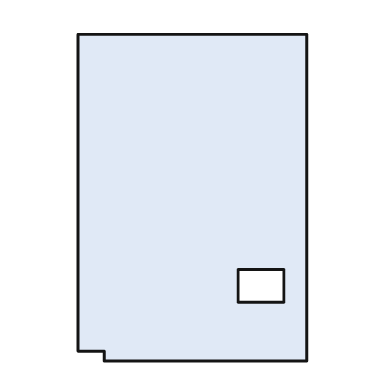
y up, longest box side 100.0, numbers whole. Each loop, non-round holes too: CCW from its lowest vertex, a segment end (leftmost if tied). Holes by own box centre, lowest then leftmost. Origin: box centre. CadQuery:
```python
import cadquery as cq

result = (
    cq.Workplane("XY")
    .moveTo(-27.0, -50.0)
    .lineTo(35.0, -50.0)
    .lineTo(35.0, 50.0)
    .lineTo(-35.0, 50.0)
    .lineTo(-35.0, -47.0)
    .lineTo(-27.0, -47.0)
    .close()
    .moveTo(14.0, -32.0)
    .lineTo(28.0, -32.0)
    .lineTo(28.0, -22.0)
    .lineTo(14.0, -22.0)
    .close()
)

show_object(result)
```